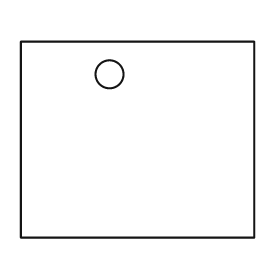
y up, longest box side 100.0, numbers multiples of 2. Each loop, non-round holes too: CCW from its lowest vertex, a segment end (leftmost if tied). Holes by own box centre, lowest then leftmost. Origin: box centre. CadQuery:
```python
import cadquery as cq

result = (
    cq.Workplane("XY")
    .moveTo(-50.0, -42.0)
    .lineTo(50.0, -42.0)
    .lineTo(50.0, 42.0)
    .lineTo(-50.0, 42.0)
    .close()
    .moveTo(-12.0, 28.0)
    .circle(6.0)
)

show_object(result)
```